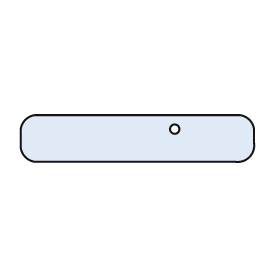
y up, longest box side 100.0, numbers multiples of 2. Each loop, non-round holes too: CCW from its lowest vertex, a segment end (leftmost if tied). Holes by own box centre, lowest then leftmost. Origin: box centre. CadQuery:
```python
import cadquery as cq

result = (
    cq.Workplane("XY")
    .moveTo(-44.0, -10.0)
    .lineTo(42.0, -10.0)
    .threePointArc((48.0, -8.0), (50.0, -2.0))
    .lineTo(50.0, 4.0)
    .threePointArc((48.0, 8.0), (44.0, 10.0))
    .lineTo(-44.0, 10.0)
    .threePointArc((-48.0, 8.0), (-50.0, 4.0))
    .lineTo(-50.0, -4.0)
    .threePointArc((-48.0, -8.0), (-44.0, -10.0))
    .close()
    .moveTo(16.0, 4.0)
    .circle(2.0)
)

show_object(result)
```